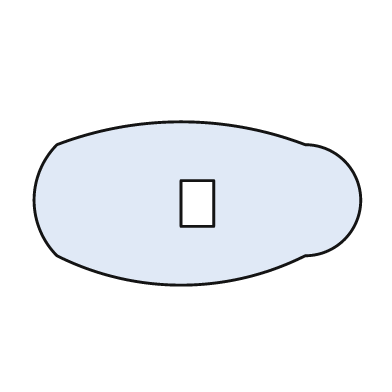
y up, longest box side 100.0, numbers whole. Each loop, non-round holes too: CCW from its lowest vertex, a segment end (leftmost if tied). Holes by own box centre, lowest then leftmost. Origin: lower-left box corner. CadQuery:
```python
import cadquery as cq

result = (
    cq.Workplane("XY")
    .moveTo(7.0, 9.0)
    .threePointArc((45.0, 0.0), (83.0, 9.0))
    .threePointArc((100.0, 26.0), (83.0, 43.0))
    .threePointArc((45.0, 50.0), (7.0, 43.0))
    .threePointArc((0.0, 26.0), (7.0, 9.0))
    .close()
    .moveTo(45.0, 18.0)
    .lineTo(55.0, 18.0)
    .lineTo(55.0, 32.0)
    .lineTo(45.0, 32.0)
    .close()
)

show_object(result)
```